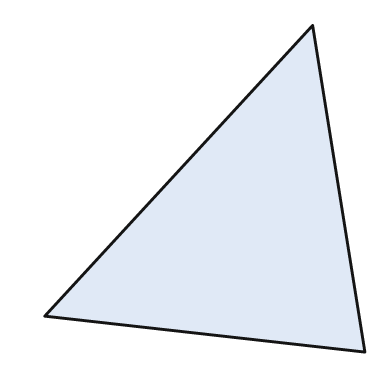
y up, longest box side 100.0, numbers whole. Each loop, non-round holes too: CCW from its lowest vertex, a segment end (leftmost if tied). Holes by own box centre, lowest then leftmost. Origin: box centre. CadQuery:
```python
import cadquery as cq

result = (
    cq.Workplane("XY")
    .moveTo(49.0, -50.0)
    .lineTo(33.0, 50.0)
    .lineTo(-49.0, -39.0)
    .close()
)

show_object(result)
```